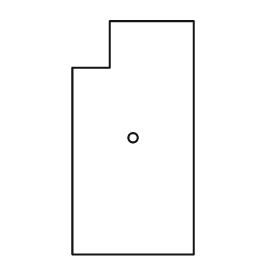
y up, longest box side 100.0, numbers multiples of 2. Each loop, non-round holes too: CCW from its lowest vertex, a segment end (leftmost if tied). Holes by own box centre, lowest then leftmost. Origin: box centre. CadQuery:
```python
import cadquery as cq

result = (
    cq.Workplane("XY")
    .moveTo(-26.0, -50.0)
    .lineTo(26.0, -50.0)
    .lineTo(26.0, 50.0)
    .lineTo(-10.0, 50.0)
    .lineTo(-10.0, 30.0)
    .lineTo(-26.0, 30.0)
    .close()
    .moveTo(0.0, 0.0)
    .circle(2.0)
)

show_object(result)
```